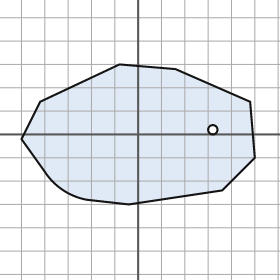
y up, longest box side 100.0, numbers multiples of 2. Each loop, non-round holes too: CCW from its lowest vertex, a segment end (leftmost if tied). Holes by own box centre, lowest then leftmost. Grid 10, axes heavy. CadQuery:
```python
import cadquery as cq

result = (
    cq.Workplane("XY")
    .moveTo(-4.0, -30.0)
    .lineTo(36.0, -24.0)
    .lineTo(50.0, -10.0)
    .lineTo(48.0, 14.0)
    .lineTo(16.0, 28.0)
    .lineTo(-8.0, 30.0)
    .lineTo(-42.0, 14.0)
    .lineTo(-50.0, -2.0)
    .lineTo(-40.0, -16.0)
    .threePointArc((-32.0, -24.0), (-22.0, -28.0))
    .close()
    .moveTo(32.0, 2.0)
    .circle(2.0)
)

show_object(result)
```